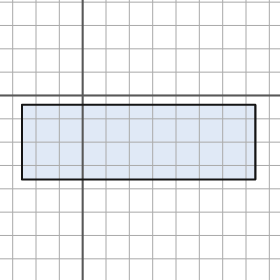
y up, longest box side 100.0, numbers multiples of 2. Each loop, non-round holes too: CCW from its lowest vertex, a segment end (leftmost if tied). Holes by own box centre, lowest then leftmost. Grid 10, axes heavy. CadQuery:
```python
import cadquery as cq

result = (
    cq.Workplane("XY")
    .moveTo(-26.0, -36.0)
    .lineTo(74.0, -36.0)
    .lineTo(74.0, -4.0)
    .lineTo(-26.0, -4.0)
    .close()
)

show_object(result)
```